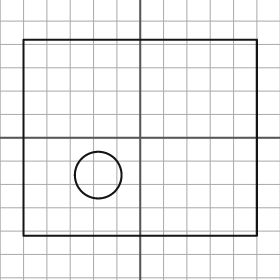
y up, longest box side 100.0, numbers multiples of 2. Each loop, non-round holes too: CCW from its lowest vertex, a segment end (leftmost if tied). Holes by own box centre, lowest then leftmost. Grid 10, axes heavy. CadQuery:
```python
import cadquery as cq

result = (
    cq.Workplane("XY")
    .moveTo(-50.0, -42.0)
    .lineTo(50.0, -42.0)
    .lineTo(50.0, 42.0)
    .lineTo(-50.0, 42.0)
    .close()
    .moveTo(-18.0, -16.0)
    .circle(10.0)
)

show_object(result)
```